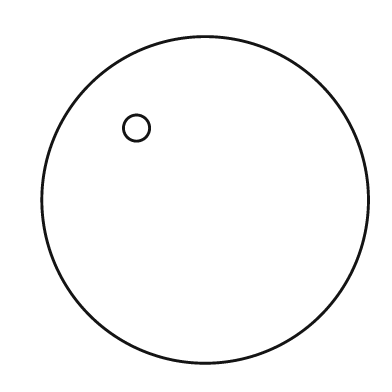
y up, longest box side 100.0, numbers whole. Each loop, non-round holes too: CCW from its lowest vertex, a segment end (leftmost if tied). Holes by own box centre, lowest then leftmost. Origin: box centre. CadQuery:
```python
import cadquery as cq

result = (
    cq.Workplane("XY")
    .moveTo(0.0, 0.0)
    .circle(50.0)
    .moveTo(-21.0, 22.0)
    .circle(4.0)
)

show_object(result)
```